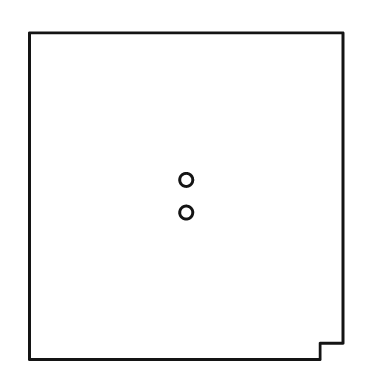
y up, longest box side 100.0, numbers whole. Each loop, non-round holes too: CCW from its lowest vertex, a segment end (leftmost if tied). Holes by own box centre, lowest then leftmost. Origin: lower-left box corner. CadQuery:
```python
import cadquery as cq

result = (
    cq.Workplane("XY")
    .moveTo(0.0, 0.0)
    .lineTo(89.0, 0.0)
    .lineTo(89.0, 5.0)
    .lineTo(96.0, 5.0)
    .lineTo(96.0, 100.0)
    .lineTo(0.0, 100.0)
    .close()
    .moveTo(48.0, 45.0)
    .circle(2.0)
    .moveTo(48.0, 55.0)
    .circle(2.0)
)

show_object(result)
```